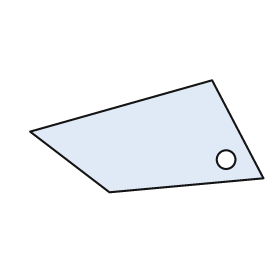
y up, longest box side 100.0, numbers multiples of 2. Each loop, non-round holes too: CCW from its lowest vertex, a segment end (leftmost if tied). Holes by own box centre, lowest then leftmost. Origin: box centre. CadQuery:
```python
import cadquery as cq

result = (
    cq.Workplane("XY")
    .moveTo(-16.0, -24.0)
    .lineTo(50.0, -18.0)
    .lineTo(28.0, 24.0)
    .lineTo(-50.0, 2.0)
    .close()
    .moveTo(34.0, -10.0)
    .circle(4.0)
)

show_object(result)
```